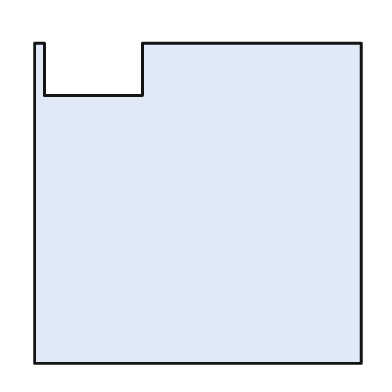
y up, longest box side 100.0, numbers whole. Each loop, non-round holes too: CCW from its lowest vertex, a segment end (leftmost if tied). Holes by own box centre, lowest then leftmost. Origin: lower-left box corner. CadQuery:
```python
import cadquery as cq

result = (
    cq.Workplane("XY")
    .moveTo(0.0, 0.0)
    .lineTo(100.0, 0.0)
    .lineTo(100.0, 98.0)
    .lineTo(33.0, 98.0)
    .lineTo(33.0, 82.0)
    .lineTo(3.0, 82.0)
    .lineTo(3.0, 98.0)
    .lineTo(0.0, 98.0)
    .close()
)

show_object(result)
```